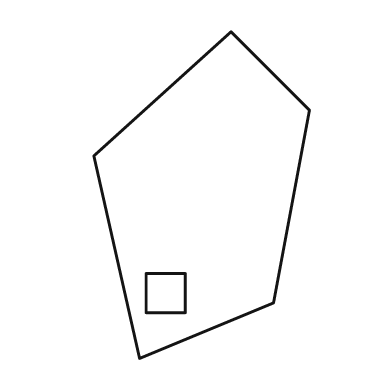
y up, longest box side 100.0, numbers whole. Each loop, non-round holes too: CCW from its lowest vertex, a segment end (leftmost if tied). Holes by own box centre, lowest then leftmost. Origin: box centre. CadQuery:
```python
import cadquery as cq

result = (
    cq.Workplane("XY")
    .moveTo(-19.0, -50.0)
    .lineTo(22.0, -33.0)
    .lineTo(33.0, 26.0)
    .lineTo(9.0, 50.0)
    .lineTo(-33.0, 12.0)
    .close()
    .moveTo(-17.0, -36.0)
    .lineTo(-5.0, -36.0)
    .lineTo(-5.0, -24.0)
    .lineTo(-17.0, -24.0)
    .close()
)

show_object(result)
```